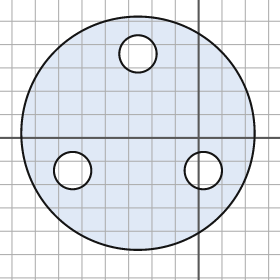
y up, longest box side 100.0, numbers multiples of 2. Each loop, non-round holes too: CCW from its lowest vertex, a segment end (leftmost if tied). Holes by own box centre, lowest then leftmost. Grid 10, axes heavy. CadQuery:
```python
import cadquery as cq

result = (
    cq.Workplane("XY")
    .moveTo(-26.0, 2.0)
    .circle(50.0)
    .moveTo(-54.0, -14.0)
    .circle(8.0)
    .moveTo(2.0, -14.0)
    .circle(8.0)
    .moveTo(-26.0, 36.0)
    .circle(8.0)
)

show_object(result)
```